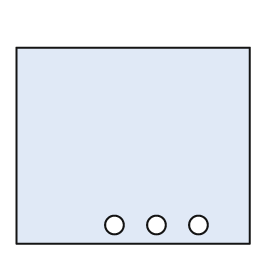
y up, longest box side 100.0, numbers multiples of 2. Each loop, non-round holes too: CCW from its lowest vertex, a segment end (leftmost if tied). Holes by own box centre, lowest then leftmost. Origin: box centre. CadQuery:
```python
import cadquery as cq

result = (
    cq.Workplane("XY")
    .moveTo(-50.0, -42.0)
    .lineTo(50.0, -42.0)
    .lineTo(50.0, 42.0)
    .lineTo(-50.0, 42.0)
    .close()
    .moveTo(-8.0, -34.0)
    .circle(4.0)
    .moveTo(10.0, -34.0)
    .circle(4.0)
    .moveTo(28.0, -34.0)
    .circle(4.0)
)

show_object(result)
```